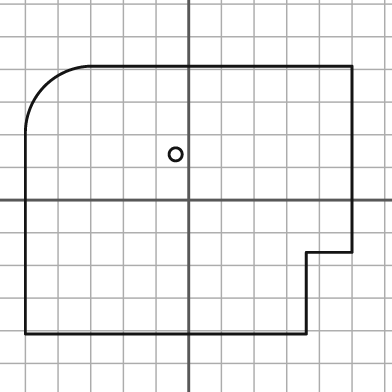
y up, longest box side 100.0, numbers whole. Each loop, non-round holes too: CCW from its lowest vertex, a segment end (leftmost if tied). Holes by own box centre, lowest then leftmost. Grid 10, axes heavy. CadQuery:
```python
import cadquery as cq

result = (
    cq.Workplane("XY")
    .moveTo(-50.0, -41.0)
    .lineTo(36.0, -41.0)
    .lineTo(36.0, -16.0)
    .lineTo(50.0, -16.0)
    .lineTo(50.0, 41.0)
    .lineTo(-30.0, 41.0)
    .threePointArc((-44.0, 35.0), (-50.0, 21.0))
    .close()
    .moveTo(-4.0, 14.0)
    .circle(2.0)
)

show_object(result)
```